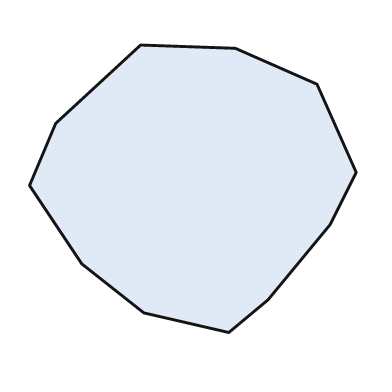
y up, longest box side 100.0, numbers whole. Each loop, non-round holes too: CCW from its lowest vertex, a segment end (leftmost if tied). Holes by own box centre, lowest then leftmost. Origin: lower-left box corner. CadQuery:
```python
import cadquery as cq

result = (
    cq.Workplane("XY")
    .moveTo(61.0, 0.0)
    .lineTo(73.0, 10.0)
    .lineTo(92.0, 33.0)
    .lineTo(100.0, 49.0)
    .lineTo(88.0, 76.0)
    .lineTo(63.0, 87.0)
    .lineTo(34.0, 88.0)
    .lineTo(8.0, 64.0)
    .lineTo(0.0, 45.0)
    .lineTo(16.0, 21.0)
    .lineTo(35.0, 6.0)
    .close()
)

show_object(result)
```